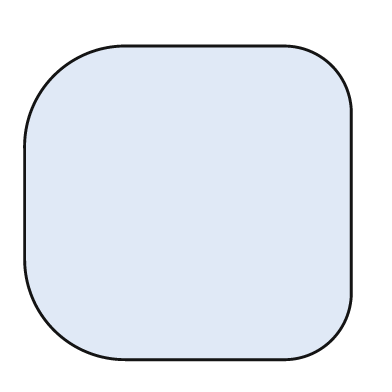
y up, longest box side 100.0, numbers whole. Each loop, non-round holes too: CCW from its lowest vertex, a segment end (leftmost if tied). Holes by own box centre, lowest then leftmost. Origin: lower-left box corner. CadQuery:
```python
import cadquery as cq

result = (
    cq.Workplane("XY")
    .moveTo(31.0, 0.0)
    .lineTo(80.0, 0.0)
    .threePointArc((94.0, 6.0), (100.0, 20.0))
    .lineTo(100.0, 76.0)
    .threePointArc((94.0, 90.0), (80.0, 96.0))
    .lineTo(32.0, 96.0)
    .threePointArc((9.0, 87.0), (0.0, 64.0))
    .lineTo(0.0, 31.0)
    .threePointArc((9.0, 9.0), (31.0, 0.0))
    .close()
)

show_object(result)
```